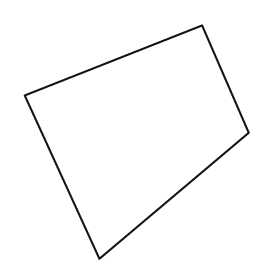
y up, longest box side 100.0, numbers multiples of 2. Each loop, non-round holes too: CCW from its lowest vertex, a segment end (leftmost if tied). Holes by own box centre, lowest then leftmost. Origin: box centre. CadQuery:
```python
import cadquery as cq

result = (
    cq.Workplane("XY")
    .moveTo(-16.0, -50.0)
    .lineTo(48.0, 4.0)
    .lineTo(28.0, 50.0)
    .lineTo(-48.0, 20.0)
    .close()
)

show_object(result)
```